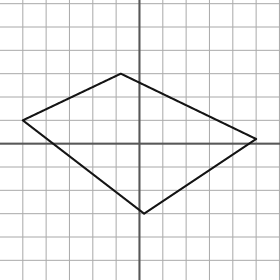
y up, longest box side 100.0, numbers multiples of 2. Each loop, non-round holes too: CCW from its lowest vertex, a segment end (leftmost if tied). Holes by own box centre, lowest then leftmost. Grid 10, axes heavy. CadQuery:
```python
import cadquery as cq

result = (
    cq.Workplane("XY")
    .moveTo(2.0, -30.0)
    .lineTo(50.0, 2.0)
    .lineTo(-8.0, 30.0)
    .lineTo(-50.0, 10.0)
    .close()
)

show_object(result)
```